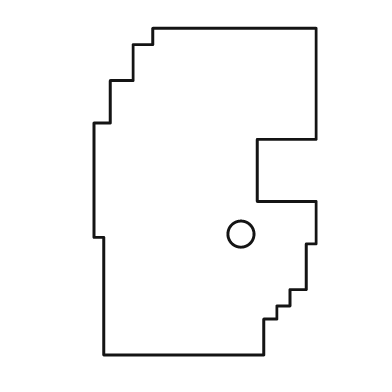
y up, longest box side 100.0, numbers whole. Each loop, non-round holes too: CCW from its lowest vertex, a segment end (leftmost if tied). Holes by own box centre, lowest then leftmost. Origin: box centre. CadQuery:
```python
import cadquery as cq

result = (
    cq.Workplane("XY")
    .moveTo(-31.0, -50.0)
    .lineTo(18.0, -50.0)
    .lineTo(18.0, -39.0)
    .lineTo(22.0, -39.0)
    .lineTo(22.0, -35.0)
    .lineTo(26.0, -35.0)
    .lineTo(26.0, -30.0)
    .lineTo(31.0, -30.0)
    .lineTo(31.0, -16.0)
    .lineTo(34.0, -16.0)
    .lineTo(34.0, -3.0)
    .lineTo(16.0, -3.0)
    .lineTo(16.0, 16.0)
    .lineTo(34.0, 16.0)
    .lineTo(34.0, 50.0)
    .lineTo(-16.0, 50.0)
    .lineTo(-16.0, 45.0)
    .lineTo(-22.0, 45.0)
    .lineTo(-22.0, 34.0)
    .lineTo(-29.0, 34.0)
    .lineTo(-29.0, 21.0)
    .lineTo(-34.0, 21.0)
    .lineTo(-34.0, -14.0)
    .lineTo(-31.0, -14.0)
    .close()
    .moveTo(11.0, -13.0)
    .circle(4.0)
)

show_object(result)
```